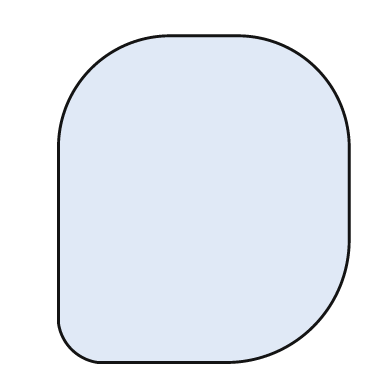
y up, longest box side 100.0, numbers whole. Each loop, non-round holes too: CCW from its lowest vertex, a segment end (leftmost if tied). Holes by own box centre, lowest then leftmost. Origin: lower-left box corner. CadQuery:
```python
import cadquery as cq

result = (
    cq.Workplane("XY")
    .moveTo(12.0, 0.0)
    .lineTo(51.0, 0.0)
    .threePointArc((78.0, 11.0), (89.0, 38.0))
    .lineTo(89.0, 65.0)
    .threePointArc((79.0, 90.0), (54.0, 100.0))
    .lineTo(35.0, 100.0)
    .threePointArc((10.0, 90.0), (0.0, 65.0))
    .lineTo(0.0, 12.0)
    .threePointArc((4.0, 4.0), (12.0, 0.0))
    .close()
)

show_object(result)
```